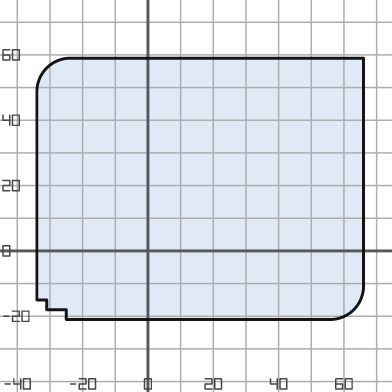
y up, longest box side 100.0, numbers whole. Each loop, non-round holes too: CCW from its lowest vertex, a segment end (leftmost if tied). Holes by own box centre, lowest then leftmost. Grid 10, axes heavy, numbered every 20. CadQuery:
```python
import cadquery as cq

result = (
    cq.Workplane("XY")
    .moveTo(-25.0, -21.0)
    .lineTo(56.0, -21.0)
    .threePointArc((63.0, -18.0), (66.0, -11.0))
    .lineTo(66.0, 59.0)
    .lineTo(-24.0, 59.0)
    .threePointArc((-31.0, 56.0), (-34.0, 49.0))
    .lineTo(-34.0, -15.0)
    .lineTo(-31.0, -15.0)
    .lineTo(-31.0, -18.0)
    .lineTo(-25.0, -18.0)
    .close()
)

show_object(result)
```